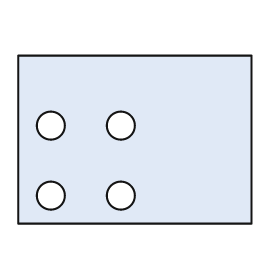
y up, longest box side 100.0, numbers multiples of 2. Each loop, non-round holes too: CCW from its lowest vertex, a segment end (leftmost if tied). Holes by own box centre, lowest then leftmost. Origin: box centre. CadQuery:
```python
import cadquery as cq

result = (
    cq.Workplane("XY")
    .moveTo(-50.0, -36.0)
    .lineTo(50.0, -36.0)
    .lineTo(50.0, 36.0)
    .lineTo(-50.0, 36.0)
    .close()
    .moveTo(-36.0, -24.0)
    .circle(6.0)
    .moveTo(-6.0, -24.0)
    .circle(6.0)
    .moveTo(-36.0, 6.0)
    .circle(6.0)
    .moveTo(-6.0, 6.0)
    .circle(6.0)
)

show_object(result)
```